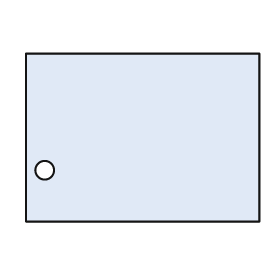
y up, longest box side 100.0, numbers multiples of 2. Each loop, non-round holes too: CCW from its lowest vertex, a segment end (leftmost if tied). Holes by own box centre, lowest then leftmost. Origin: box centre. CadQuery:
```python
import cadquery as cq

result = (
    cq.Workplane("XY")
    .moveTo(-50.0, -36.0)
    .lineTo(50.0, -36.0)
    .lineTo(50.0, 36.0)
    .lineTo(-50.0, 36.0)
    .close()
    .moveTo(-42.0, -14.0)
    .circle(4.0)
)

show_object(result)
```